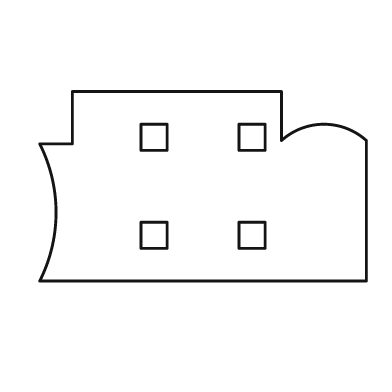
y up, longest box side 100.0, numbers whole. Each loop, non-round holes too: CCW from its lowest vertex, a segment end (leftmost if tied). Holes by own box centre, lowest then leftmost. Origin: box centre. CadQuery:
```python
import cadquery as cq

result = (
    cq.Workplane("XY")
    .moveTo(-50.0, -29.0)
    .lineTo(50.0, -29.0)
    .lineTo(50.0, 14.0)
    .threePointArc((37.0, 19.0), (24.0, 14.0))
    .lineTo(24.0, 29.0)
    .lineTo(-40.0, 29.0)
    .lineTo(-40.0, 13.0)
    .lineTo(-50.0, 13.0)
    .threePointArc((-45.0, -8.0), (-50.0, -29.0))
    .close()
    .moveTo(-19.0, -19.0)
    .lineTo(-11.0, -19.0)
    .lineTo(-11.0, -11.0)
    .lineTo(-19.0, -11.0)
    .close()
    .moveTo(11.0, -19.0)
    .lineTo(19.0, -19.0)
    .lineTo(19.0, -11.0)
    .lineTo(11.0, -11.0)
    .close()
    .moveTo(-19.0, 11.0)
    .lineTo(-11.0, 11.0)
    .lineTo(-11.0, 19.0)
    .lineTo(-19.0, 19.0)
    .close()
    .moveTo(11.0, 11.0)
    .lineTo(19.0, 11.0)
    .lineTo(19.0, 19.0)
    .lineTo(11.0, 19.0)
    .close()
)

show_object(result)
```